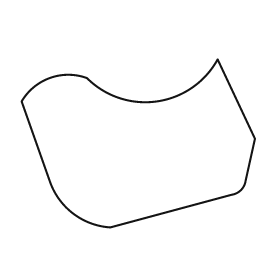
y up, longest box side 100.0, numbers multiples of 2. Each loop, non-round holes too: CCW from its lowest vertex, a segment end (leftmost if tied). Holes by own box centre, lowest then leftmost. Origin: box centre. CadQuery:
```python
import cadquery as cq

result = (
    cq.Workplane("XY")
    .moveTo(-12.0, -36.0)
    .lineTo(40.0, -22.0)
    .threePointArc((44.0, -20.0), (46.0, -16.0))
    .lineTo(50.0, 2.0)
    .lineTo(34.0, 36.0)
    .threePointArc((8.0, 18.0), (-22.0, 28.0))
    .threePointArc((-38.0, 28.0), (-50.0, 18.0))
    .lineTo(-38.0, -16.0)
    .threePointArc((-28.0, -30.0), (-12.0, -36.0))
    .close()
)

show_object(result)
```